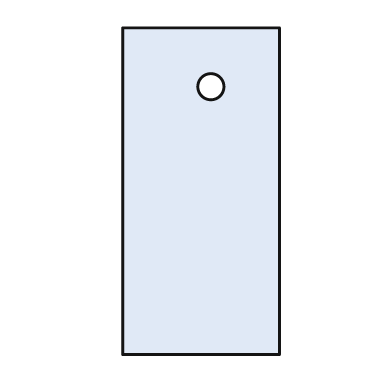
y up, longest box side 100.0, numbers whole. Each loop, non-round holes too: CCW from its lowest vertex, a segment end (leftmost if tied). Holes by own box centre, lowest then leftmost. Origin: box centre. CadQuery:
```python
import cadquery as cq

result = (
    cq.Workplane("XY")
    .moveTo(-24.0, -50.0)
    .lineTo(24.0, -50.0)
    .lineTo(24.0, 50.0)
    .lineTo(-24.0, 50.0)
    .close()
    .moveTo(3.0, 32.0)
    .circle(4.0)
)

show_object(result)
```